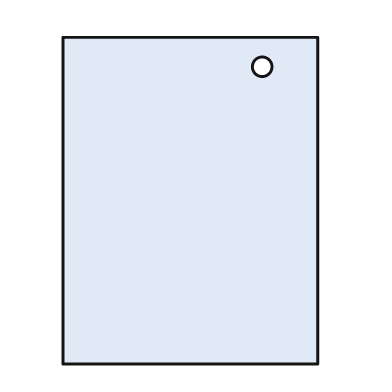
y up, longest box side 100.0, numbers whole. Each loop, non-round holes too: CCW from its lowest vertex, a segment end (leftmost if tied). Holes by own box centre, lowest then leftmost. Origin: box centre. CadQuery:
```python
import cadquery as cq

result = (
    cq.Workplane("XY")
    .moveTo(-39.0, -50.0)
    .lineTo(39.0, -50.0)
    .lineTo(39.0, 50.0)
    .lineTo(-39.0, 50.0)
    .close()
    .moveTo(22.0, 41.0)
    .circle(3.0)
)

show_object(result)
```